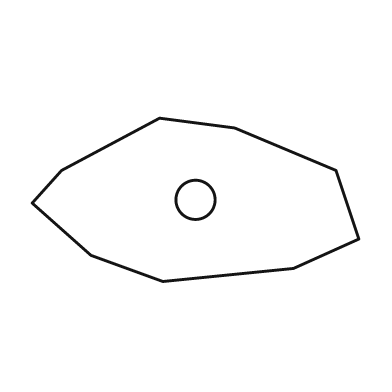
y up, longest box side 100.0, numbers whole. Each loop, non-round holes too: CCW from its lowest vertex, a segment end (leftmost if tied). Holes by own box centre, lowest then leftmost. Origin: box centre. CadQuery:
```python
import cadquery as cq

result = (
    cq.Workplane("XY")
    .moveTo(-10.0, -25.0)
    .lineTo(30.0, -21.0)
    .lineTo(50.0, -12.0)
    .lineTo(43.0, 9.0)
    .lineTo(12.0, 22.0)
    .lineTo(-11.0, 25.0)
    .lineTo(-41.0, 9.0)
    .lineTo(-50.0, -1.0)
    .lineTo(-32.0, -17.0)
    .close()
    .moveTo(0.0, 0.0)
    .circle(6.0)
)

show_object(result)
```